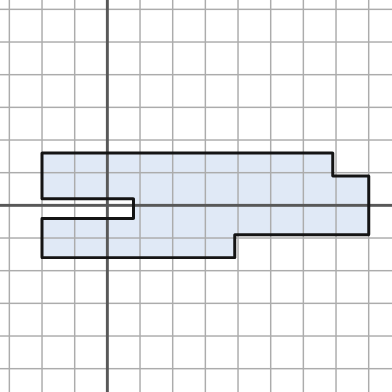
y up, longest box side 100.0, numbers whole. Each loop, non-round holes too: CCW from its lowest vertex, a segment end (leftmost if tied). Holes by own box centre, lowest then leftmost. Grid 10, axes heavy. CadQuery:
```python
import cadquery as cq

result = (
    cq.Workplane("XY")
    .moveTo(-20.0, -16.0)
    .lineTo(39.0, -16.0)
    .lineTo(39.0, -9.0)
    .lineTo(80.0, -9.0)
    .lineTo(80.0, 9.0)
    .lineTo(69.0, 9.0)
    .lineTo(69.0, 16.0)
    .lineTo(-20.0, 16.0)
    .lineTo(-20.0, 2.0)
    .lineTo(8.0, 2.0)
    .lineTo(8.0, -4.0)
    .lineTo(-20.0, -4.0)
    .close()
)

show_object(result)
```